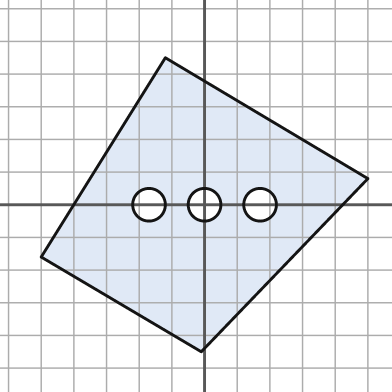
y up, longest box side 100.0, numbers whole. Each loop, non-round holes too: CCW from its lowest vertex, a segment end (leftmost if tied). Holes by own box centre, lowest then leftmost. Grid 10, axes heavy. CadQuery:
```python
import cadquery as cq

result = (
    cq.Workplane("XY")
    .moveTo(-1.0, -45.0)
    .lineTo(50.0, 8.0)
    .lineTo(-12.0, 45.0)
    .lineTo(-50.0, -16.0)
    .close()
    .moveTo(-17.0, 0.0)
    .circle(5.0)
    .moveTo(0.0, 0.0)
    .circle(5.0)
    .moveTo(17.0, 0.0)
    .circle(5.0)
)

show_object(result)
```